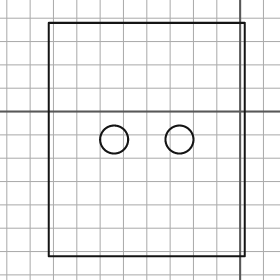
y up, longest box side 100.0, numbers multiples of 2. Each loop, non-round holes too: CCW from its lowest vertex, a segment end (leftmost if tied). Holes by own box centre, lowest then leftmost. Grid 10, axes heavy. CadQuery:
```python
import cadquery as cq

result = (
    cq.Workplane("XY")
    .moveTo(-82.0, -62.0)
    .lineTo(2.0, -62.0)
    .lineTo(2.0, 38.0)
    .lineTo(-82.0, 38.0)
    .close()
    .moveTo(-54.0, -12.0)
    .circle(6.0)
    .moveTo(-26.0, -12.0)
    .circle(6.0)
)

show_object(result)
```